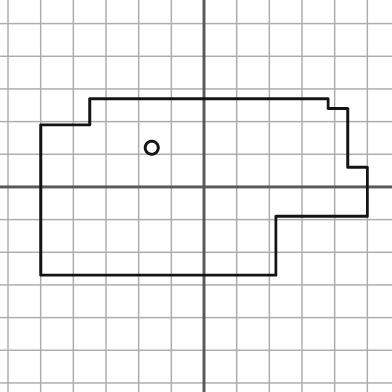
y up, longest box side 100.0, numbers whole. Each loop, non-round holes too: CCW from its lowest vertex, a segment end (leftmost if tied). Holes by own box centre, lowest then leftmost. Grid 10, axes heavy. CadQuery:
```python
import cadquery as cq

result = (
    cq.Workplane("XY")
    .moveTo(-50.0, -27.0)
    .lineTo(22.0, -27.0)
    .lineTo(22.0, -9.0)
    .lineTo(50.0, -9.0)
    .lineTo(50.0, 6.0)
    .lineTo(44.0, 6.0)
    .lineTo(44.0, 24.0)
    .lineTo(38.0, 24.0)
    .lineTo(38.0, 27.0)
    .lineTo(-35.0, 27.0)
    .lineTo(-35.0, 19.0)
    .lineTo(-50.0, 19.0)
    .close()
    .moveTo(-16.0, 12.0)
    .circle(2.0)
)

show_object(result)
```